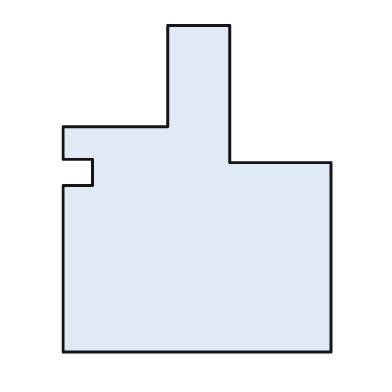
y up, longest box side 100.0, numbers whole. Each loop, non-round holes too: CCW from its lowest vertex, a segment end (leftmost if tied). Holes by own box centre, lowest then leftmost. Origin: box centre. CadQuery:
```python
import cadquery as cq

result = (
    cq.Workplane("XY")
    .moveTo(-41.0, -50.0)
    .lineTo(41.0, -50.0)
    .lineTo(41.0, 8.0)
    .lineTo(10.0, 8.0)
    .lineTo(10.0, 50.0)
    .lineTo(-9.0, 50.0)
    .lineTo(-9.0, 19.0)
    .lineTo(-41.0, 19.0)
    .lineTo(-41.0, 9.0)
    .lineTo(-32.0, 9.0)
    .lineTo(-32.0, 1.0)
    .lineTo(-41.0, 1.0)
    .close()
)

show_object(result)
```